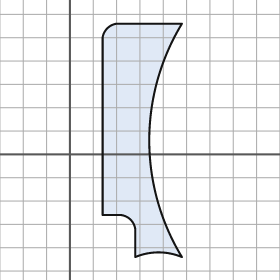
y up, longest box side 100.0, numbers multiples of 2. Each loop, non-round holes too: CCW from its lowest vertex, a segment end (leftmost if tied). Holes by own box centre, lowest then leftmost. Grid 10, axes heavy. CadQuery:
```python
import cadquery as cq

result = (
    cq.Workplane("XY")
    .moveTo(28.0, -44.0)
    .threePointArc((38.0, -42.0), (48.0, -44.0))
    .threePointArc((34.0, 6.0), (48.0, 56.0))
    .lineTo(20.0, 56.0)
    .threePointArc((16.0, 54.0), (14.0, 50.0))
    .lineTo(14.0, -26.0)
    .lineTo(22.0, -26.0)
    .threePointArc((26.0, -28.0), (28.0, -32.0))
    .close()
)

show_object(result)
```